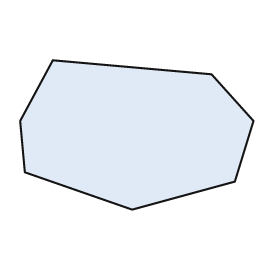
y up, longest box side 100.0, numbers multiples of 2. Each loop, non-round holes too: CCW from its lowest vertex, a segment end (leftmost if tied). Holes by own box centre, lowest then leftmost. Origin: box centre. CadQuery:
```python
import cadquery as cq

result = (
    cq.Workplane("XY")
    .moveTo(-2.0, -32.0)
    .lineTo(42.0, -20.0)
    .lineTo(50.0, 6.0)
    .lineTo(32.0, 26.0)
    .lineTo(-36.0, 32.0)
    .lineTo(-50.0, 6.0)
    .lineTo(-48.0, -16.0)
    .close()
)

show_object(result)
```